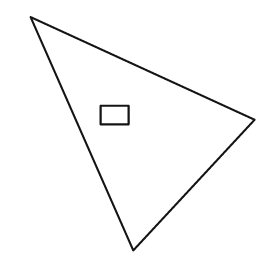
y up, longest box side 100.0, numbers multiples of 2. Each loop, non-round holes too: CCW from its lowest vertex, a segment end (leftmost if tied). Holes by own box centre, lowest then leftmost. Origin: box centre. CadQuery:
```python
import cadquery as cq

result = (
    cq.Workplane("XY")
    .moveTo(-4.0, -50.0)
    .lineTo(48.0, 6.0)
    .lineTo(-48.0, 50.0)
    .close()
    .moveTo(-18.0, 4.0)
    .lineTo(-6.0, 4.0)
    .lineTo(-6.0, 12.0)
    .lineTo(-18.0, 12.0)
    .close()
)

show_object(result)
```